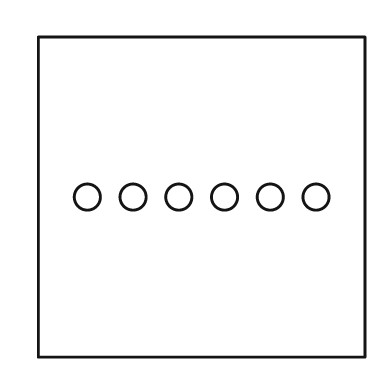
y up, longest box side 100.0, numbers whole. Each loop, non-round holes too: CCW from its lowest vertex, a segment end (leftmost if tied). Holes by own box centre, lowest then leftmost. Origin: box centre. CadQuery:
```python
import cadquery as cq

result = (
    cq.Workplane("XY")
    .moveTo(-50.0, -49.0)
    .lineTo(50.0, -49.0)
    .lineTo(50.0, 49.0)
    .lineTo(-50.0, 49.0)
    .close()
    .moveTo(-35.0, 0.0)
    .circle(4.0)
    .moveTo(-21.0, 0.0)
    .circle(4.0)
    .moveTo(-7.0, 0.0)
    .circle(4.0)
    .moveTo(7.0, 0.0)
    .circle(4.0)
    .moveTo(21.0, 0.0)
    .circle(4.0)
    .moveTo(35.0, 0.0)
    .circle(4.0)
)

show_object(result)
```